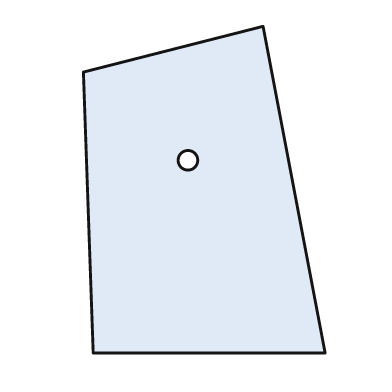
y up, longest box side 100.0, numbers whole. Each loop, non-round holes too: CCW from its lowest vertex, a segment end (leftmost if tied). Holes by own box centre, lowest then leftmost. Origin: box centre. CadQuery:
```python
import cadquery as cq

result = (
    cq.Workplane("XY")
    .moveTo(-34.0, -50.0)
    .lineTo(37.0, -50.0)
    .lineTo(18.0, 50.0)
    .lineTo(-37.0, 36.0)
    .close()
    .moveTo(-5.0, 9.0)
    .circle(3.0)
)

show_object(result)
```